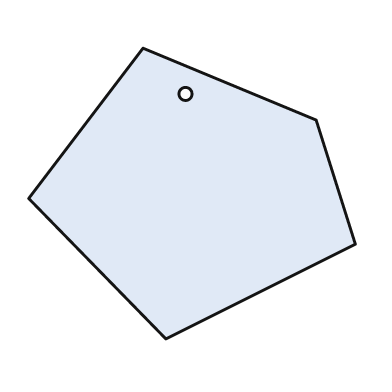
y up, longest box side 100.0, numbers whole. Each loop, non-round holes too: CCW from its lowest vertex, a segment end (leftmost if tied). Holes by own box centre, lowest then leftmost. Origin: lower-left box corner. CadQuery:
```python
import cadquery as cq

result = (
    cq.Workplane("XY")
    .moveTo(42.0, 0.0)
    .lineTo(100.0, 29.0)
    .lineTo(88.0, 67.0)
    .lineTo(35.0, 89.0)
    .lineTo(0.0, 43.0)
    .close()
    .moveTo(48.0, 75.0)
    .circle(2.0)
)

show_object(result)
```